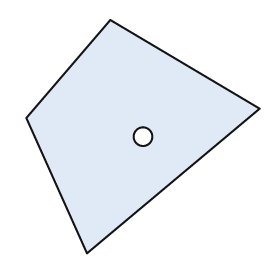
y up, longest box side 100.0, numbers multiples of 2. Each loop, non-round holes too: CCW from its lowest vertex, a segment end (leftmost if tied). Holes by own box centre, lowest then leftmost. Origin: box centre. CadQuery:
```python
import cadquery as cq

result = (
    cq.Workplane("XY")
    .moveTo(-24.0, -50.0)
    .lineTo(50.0, 12.0)
    .lineTo(-14.0, 50.0)
    .lineTo(-50.0, 8.0)
    .close()
    .moveTo(0.0, 0.0)
    .circle(4.0)
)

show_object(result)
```